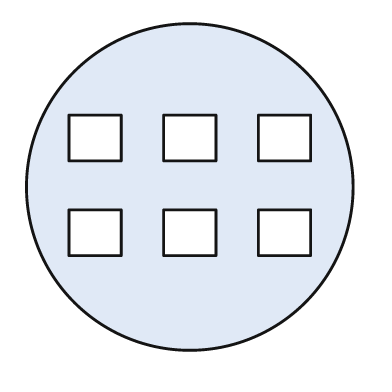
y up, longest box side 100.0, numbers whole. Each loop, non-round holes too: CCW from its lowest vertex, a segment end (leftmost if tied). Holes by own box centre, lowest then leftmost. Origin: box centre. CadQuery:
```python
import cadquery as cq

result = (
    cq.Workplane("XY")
    .moveTo(0.0, 0.0)
    .circle(50.0)
    .moveTo(-37.0, -21.0)
    .lineTo(-21.0, -21.0)
    .lineTo(-21.0, -7.0)
    .lineTo(-37.0, -7.0)
    .close()
    .moveTo(-8.0, -21.0)
    .lineTo(8.0, -21.0)
    .lineTo(8.0, -7.0)
    .lineTo(-8.0, -7.0)
    .close()
    .moveTo(21.0, -21.0)
    .lineTo(37.0, -21.0)
    .lineTo(37.0, -7.0)
    .lineTo(21.0, -7.0)
    .close()
    .moveTo(-37.0, 8.0)
    .lineTo(-21.0, 8.0)
    .lineTo(-21.0, 22.0)
    .lineTo(-37.0, 22.0)
    .close()
    .moveTo(-8.0, 8.0)
    .lineTo(8.0, 8.0)
    .lineTo(8.0, 22.0)
    .lineTo(-8.0, 22.0)
    .close()
    .moveTo(21.0, 8.0)
    .lineTo(37.0, 8.0)
    .lineTo(37.0, 22.0)
    .lineTo(21.0, 22.0)
    .close()
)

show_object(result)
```